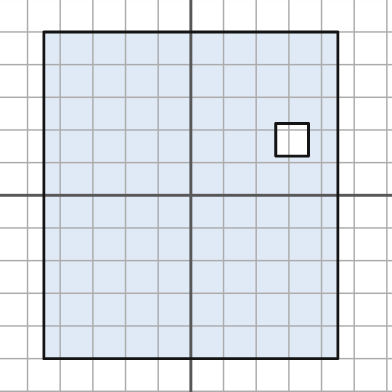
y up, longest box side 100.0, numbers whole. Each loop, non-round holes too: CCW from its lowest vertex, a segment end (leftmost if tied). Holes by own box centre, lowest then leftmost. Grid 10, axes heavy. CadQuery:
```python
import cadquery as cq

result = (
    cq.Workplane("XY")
    .moveTo(-45.0, -50.0)
    .lineTo(45.0, -50.0)
    .lineTo(45.0, 50.0)
    .lineTo(-45.0, 50.0)
    .close()
    .moveTo(26.0, 12.0)
    .lineTo(36.0, 12.0)
    .lineTo(36.0, 22.0)
    .lineTo(26.0, 22.0)
    .close()
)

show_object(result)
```